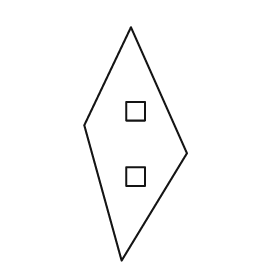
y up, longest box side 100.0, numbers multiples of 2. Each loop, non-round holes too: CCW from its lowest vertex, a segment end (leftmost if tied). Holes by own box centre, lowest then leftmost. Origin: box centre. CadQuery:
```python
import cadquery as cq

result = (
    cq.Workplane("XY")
    .moveTo(-6.0, -50.0)
    .lineTo(22.0, -4.0)
    .lineTo(-2.0, 50.0)
    .lineTo(-22.0, 8.0)
    .close()
    .moveTo(-4.0, -18.0)
    .lineTo(4.0, -18.0)
    .lineTo(4.0, -10.0)
    .lineTo(-4.0, -10.0)
    .close()
    .moveTo(-4.0, 10.0)
    .lineTo(4.0, 10.0)
    .lineTo(4.0, 18.0)
    .lineTo(-4.0, 18.0)
    .close()
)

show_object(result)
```